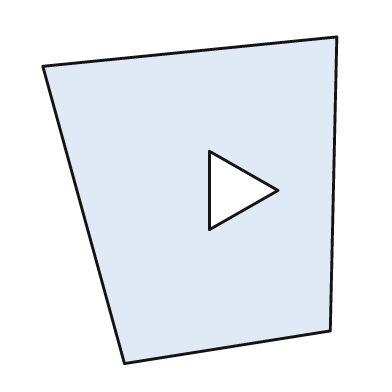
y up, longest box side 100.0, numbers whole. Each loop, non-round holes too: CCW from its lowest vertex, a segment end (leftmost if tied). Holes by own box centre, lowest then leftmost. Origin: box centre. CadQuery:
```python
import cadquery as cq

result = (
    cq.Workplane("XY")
    .moveTo(-20.0, -50.0)
    .lineTo(43.0, -40.0)
    .lineTo(45.0, 50.0)
    .lineTo(-45.0, 41.0)
    .close()
    .moveTo(6.0, -9.0)
    .lineTo(27.0, 3.0)
    .lineTo(6.0, 15.0)
    .close()
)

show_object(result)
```